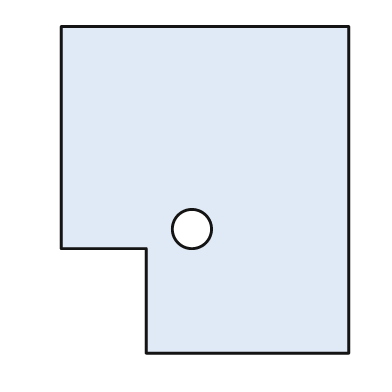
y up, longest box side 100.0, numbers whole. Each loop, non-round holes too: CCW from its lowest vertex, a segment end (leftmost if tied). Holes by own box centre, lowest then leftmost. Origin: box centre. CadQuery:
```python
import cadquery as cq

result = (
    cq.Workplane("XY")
    .moveTo(-18.0, -50.0)
    .lineTo(44.0, -50.0)
    .lineTo(44.0, 50.0)
    .lineTo(-44.0, 50.0)
    .lineTo(-44.0, -18.0)
    .lineTo(-18.0, -18.0)
    .close()
    .moveTo(-4.0, -12.0)
    .circle(6.0)
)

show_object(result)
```